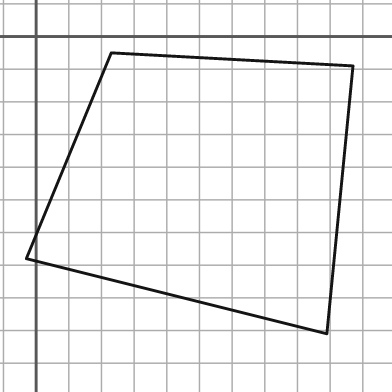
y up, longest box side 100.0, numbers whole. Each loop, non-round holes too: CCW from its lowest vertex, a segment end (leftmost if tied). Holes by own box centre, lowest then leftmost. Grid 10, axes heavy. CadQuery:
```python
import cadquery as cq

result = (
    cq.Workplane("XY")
    .moveTo(89.0, -91.0)
    .lineTo(97.0, -9.0)
    .lineTo(23.0, -5.0)
    .lineTo(-3.0, -68.0)
    .close()
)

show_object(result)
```